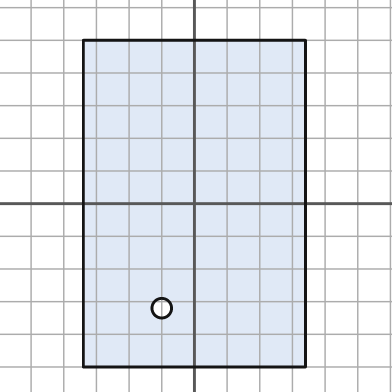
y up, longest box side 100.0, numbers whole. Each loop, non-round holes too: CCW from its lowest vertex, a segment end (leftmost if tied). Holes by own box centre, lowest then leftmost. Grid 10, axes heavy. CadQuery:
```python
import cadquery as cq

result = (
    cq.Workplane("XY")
    .moveTo(-34.0, -50.0)
    .lineTo(34.0, -50.0)
    .lineTo(34.0, 50.0)
    .lineTo(-34.0, 50.0)
    .close()
    .moveTo(-10.0, -32.0)
    .circle(3.0)
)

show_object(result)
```